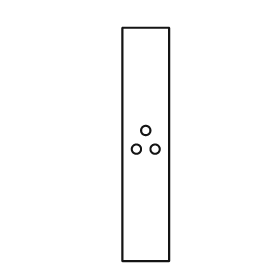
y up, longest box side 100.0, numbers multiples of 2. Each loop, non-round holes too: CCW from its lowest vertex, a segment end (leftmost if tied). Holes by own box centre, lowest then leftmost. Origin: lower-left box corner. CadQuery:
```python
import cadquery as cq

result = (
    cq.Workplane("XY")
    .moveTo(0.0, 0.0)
    .lineTo(20.0, 0.0)
    .lineTo(20.0, 100.0)
    .lineTo(0.0, 100.0)
    .close()
    .moveTo(6.0, 48.0)
    .circle(2.0)
    .moveTo(14.0, 48.0)
    .circle(2.0)
    .moveTo(10.0, 56.0)
    .circle(2.0)
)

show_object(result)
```